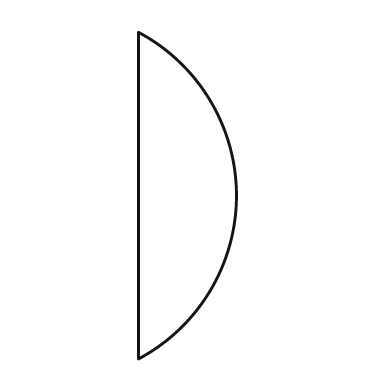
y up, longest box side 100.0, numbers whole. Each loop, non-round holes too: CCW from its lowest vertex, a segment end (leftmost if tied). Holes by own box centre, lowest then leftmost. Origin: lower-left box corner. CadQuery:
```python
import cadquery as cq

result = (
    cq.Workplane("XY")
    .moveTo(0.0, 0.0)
    .threePointArc((30.0, 50.0), (0.0, 100.0))
    .close()
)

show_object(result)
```